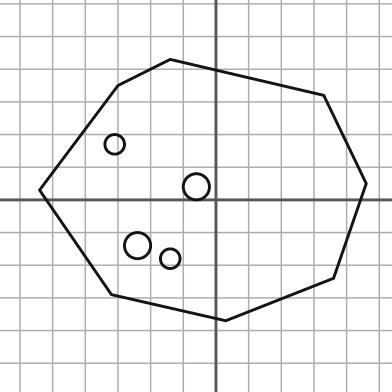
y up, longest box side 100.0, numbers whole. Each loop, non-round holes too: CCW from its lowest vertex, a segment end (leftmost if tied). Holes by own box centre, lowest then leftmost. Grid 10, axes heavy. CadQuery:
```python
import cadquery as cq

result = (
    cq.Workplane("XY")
    .moveTo(3.0, -37.0)
    .lineTo(36.0, -24.0)
    .lineTo(46.0, 5.0)
    .lineTo(33.0, 32.0)
    .lineTo(-14.0, 43.0)
    .lineTo(-30.0, 35.0)
    .lineTo(-54.0, 3.0)
    .lineTo(-32.0, -29.0)
    .close()
    .moveTo(-14.0, -18.0)
    .circle(3.0)
    .moveTo(-24.0, -14.0)
    .circle(4.0)
    .moveTo(-6.0, 4.0)
    .circle(4.0)
    .moveTo(-31.0, 17.0)
    .circle(3.0)
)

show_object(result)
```